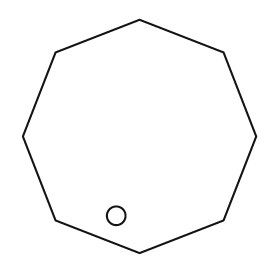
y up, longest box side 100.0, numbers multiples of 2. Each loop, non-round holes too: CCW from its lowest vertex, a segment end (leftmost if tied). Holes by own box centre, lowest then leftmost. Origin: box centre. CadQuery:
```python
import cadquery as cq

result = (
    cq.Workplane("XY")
    .moveTo(0.0, -50.0)
    .lineTo(36.0, -36.0)
    .lineTo(50.0, 0.0)
    .lineTo(36.0, 36.0)
    .lineTo(0.0, 50.0)
    .lineTo(-36.0, 36.0)
    .lineTo(-50.0, 0.0)
    .lineTo(-36.0, -36.0)
    .close()
    .moveTo(-10.0, -34.0)
    .circle(4.0)
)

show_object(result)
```